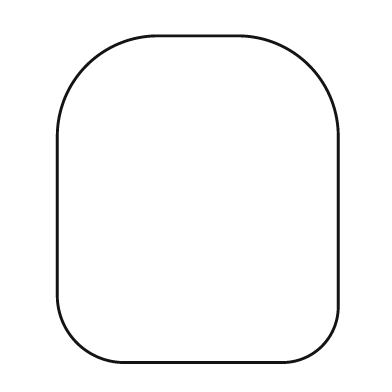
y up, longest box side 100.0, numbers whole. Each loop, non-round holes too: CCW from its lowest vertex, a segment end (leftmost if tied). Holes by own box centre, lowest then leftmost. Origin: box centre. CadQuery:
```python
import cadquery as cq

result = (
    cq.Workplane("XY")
    .moveTo(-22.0, -50.0)
    .lineTo(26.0, -50.0)
    .threePointArc((38.0, -45.0), (43.0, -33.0))
    .lineTo(43.0, 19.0)
    .threePointArc((34.0, 41.0), (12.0, 50.0))
    .lineTo(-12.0, 50.0)
    .threePointArc((-34.0, 41.0), (-43.0, 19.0))
    .lineTo(-43.0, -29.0)
    .threePointArc((-37.0, -44.0), (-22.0, -50.0))
    .close()
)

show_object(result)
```